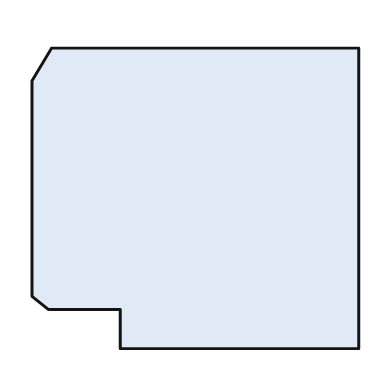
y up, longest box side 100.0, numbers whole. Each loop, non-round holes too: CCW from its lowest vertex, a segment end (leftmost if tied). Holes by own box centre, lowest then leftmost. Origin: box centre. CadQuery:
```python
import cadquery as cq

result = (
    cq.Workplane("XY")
    .moveTo(-23.0, -46.0)
    .lineTo(50.0, -46.0)
    .lineTo(50.0, 46.0)
    .lineTo(-44.0, 46.0)
    .lineTo(-50.0, 36.0)
    .lineTo(-50.0, -30.0)
    .lineTo(-45.0, -34.0)
    .lineTo(-23.0, -34.0)
    .close()
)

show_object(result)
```